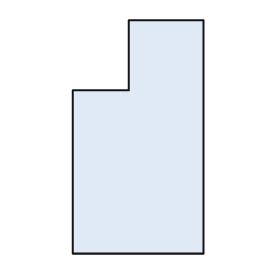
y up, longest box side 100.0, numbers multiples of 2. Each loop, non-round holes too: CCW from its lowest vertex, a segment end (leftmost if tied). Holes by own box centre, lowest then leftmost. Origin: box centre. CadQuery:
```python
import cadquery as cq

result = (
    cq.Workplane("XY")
    .moveTo(-28.0, -50.0)
    .lineTo(28.0, -50.0)
    .lineTo(28.0, 50.0)
    .lineTo(-4.0, 50.0)
    .lineTo(-4.0, 20.0)
    .lineTo(-28.0, 20.0)
    .close()
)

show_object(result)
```